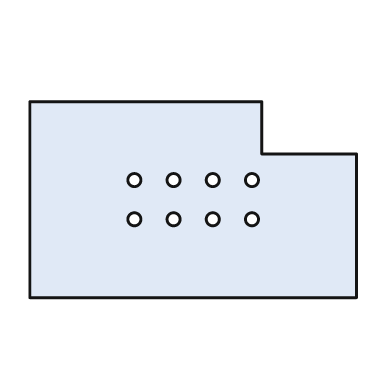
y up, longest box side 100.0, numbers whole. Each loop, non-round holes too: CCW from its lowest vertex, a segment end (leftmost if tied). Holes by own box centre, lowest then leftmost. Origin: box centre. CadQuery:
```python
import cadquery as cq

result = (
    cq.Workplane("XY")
    .moveTo(-50.0, -30.0)
    .lineTo(50.0, -30.0)
    .lineTo(50.0, 14.0)
    .lineTo(21.0, 14.0)
    .lineTo(21.0, 30.0)
    .lineTo(-50.0, 30.0)
    .close()
    .moveTo(-18.0, -6.0)
    .circle(2.0)
    .moveTo(-6.0, -6.0)
    .circle(2.0)
    .moveTo(6.0, -6.0)
    .circle(2.0)
    .moveTo(18.0, -6.0)
    .circle(2.0)
    .moveTo(-18.0, 6.0)
    .circle(2.0)
    .moveTo(-6.0, 6.0)
    .circle(2.0)
    .moveTo(6.0, 6.0)
    .circle(2.0)
    .moveTo(18.0, 6.0)
    .circle(2.0)
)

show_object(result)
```